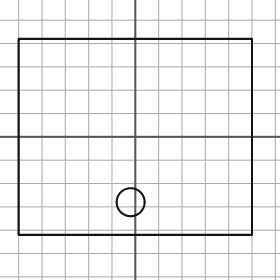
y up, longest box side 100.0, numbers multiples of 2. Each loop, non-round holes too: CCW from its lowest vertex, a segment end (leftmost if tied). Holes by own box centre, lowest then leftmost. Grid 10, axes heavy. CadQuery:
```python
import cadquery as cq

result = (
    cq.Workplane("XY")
    .moveTo(-50.0, -42.0)
    .lineTo(50.0, -42.0)
    .lineTo(50.0, 42.0)
    .lineTo(-50.0, 42.0)
    .close()
    .moveTo(-2.0, -28.0)
    .circle(6.0)
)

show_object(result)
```